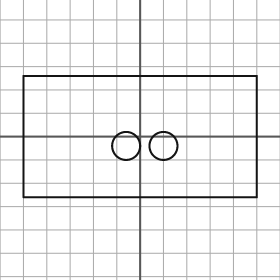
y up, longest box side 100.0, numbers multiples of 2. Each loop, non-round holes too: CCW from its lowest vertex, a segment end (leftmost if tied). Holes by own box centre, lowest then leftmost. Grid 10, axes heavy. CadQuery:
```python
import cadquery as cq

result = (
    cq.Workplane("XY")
    .moveTo(-50.0, -26.0)
    .lineTo(50.0, -26.0)
    .lineTo(50.0, 26.0)
    .lineTo(-50.0, 26.0)
    .close()
    .moveTo(-6.0, -4.0)
    .circle(6.0)
    .moveTo(10.0, -4.0)
    .circle(6.0)
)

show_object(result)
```